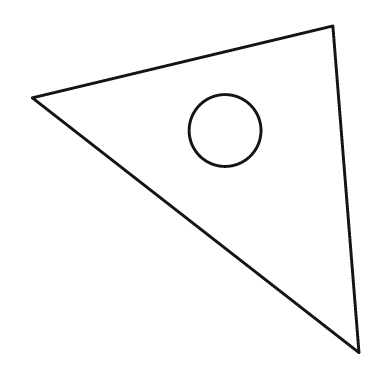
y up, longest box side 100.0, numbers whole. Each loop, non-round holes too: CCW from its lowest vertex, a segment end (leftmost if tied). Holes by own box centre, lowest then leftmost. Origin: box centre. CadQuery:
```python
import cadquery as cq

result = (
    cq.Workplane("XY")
    .moveTo(50.0, -50.0)
    .lineTo(42.0, 50.0)
    .lineTo(-50.0, 28.0)
    .close()
    .moveTo(9.0, 18.0)
    .circle(11.0)
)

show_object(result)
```